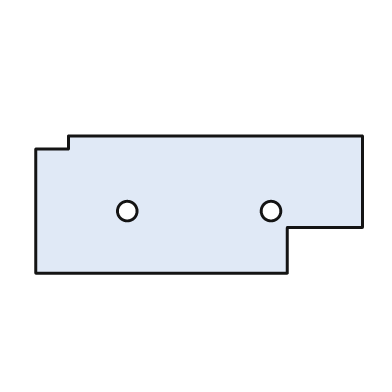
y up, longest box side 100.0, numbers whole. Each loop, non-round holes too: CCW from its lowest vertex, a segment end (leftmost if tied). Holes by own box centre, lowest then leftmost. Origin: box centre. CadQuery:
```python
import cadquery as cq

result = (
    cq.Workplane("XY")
    .moveTo(-50.0, -21.0)
    .lineTo(27.0, -21.0)
    .lineTo(27.0, -7.0)
    .lineTo(50.0, -7.0)
    .lineTo(50.0, 21.0)
    .lineTo(-40.0, 21.0)
    .lineTo(-40.0, 17.0)
    .lineTo(-50.0, 17.0)
    .close()
    .moveTo(-22.0, -2.0)
    .circle(3.0)
    .moveTo(22.0, -2.0)
    .circle(3.0)
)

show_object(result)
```